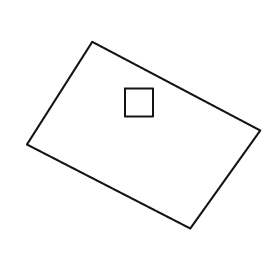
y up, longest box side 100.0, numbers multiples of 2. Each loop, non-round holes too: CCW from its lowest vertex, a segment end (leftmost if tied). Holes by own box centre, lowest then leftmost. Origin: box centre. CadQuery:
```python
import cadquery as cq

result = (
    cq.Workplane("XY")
    .moveTo(20.0, -40.0)
    .lineTo(50.0, 2.0)
    .lineTo(-22.0, 40.0)
    .lineTo(-50.0, -4.0)
    .close()
    .moveTo(-8.0, 8.0)
    .lineTo(4.0, 8.0)
    .lineTo(4.0, 20.0)
    .lineTo(-8.0, 20.0)
    .close()
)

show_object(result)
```